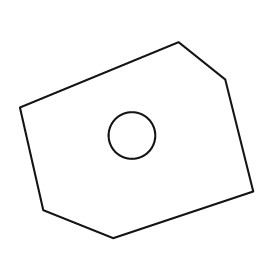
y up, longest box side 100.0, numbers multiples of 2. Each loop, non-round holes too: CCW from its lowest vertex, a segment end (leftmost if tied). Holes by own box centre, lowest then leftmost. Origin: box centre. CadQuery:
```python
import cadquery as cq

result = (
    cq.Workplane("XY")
    .moveTo(-10.0, -42.0)
    .lineTo(50.0, -22.0)
    .lineTo(38.0, 26.0)
    .lineTo(18.0, 42.0)
    .lineTo(-50.0, 14.0)
    .lineTo(-40.0, -30.0)
    .close()
    .moveTo(-2.0, 2.0)
    .circle(10.0)
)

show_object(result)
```